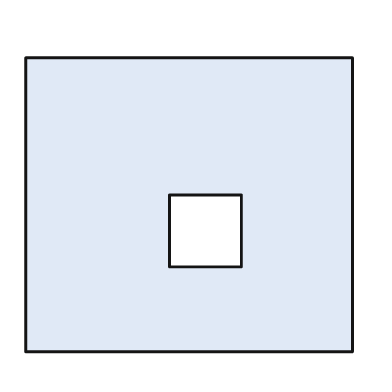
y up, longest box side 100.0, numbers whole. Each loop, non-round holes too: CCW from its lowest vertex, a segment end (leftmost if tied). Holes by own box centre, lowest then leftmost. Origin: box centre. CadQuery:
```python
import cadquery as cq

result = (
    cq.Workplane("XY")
    .moveTo(-50.0, -45.0)
    .lineTo(50.0, -45.0)
    .lineTo(50.0, 45.0)
    .lineTo(-50.0, 45.0)
    .close()
    .moveTo(-6.0, -19.0)
    .lineTo(16.0, -19.0)
    .lineTo(16.0, 3.0)
    .lineTo(-6.0, 3.0)
    .close()
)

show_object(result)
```